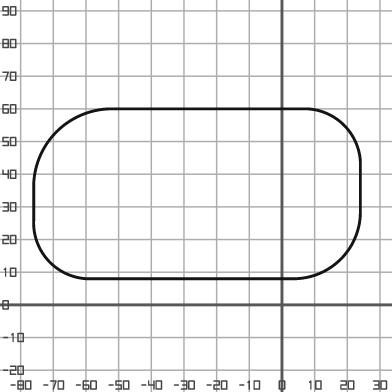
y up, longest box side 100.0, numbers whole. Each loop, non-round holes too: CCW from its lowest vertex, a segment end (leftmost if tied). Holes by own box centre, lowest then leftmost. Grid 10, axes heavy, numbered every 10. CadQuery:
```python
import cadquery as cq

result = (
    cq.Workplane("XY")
    .moveTo(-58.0, 8.0)
    .lineTo(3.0, 8.0)
    .threePointArc((18.0, 14.0), (24.0, 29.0))
    .lineTo(24.0, 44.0)
    .threePointArc((19.0, 55.0), (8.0, 60.0))
    .lineTo(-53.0, 60.0)
    .threePointArc((-69.0, 53.0), (-76.0, 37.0))
    .lineTo(-76.0, 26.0)
    .threePointArc((-71.0, 13.0), (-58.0, 8.0))
    .close()
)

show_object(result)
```